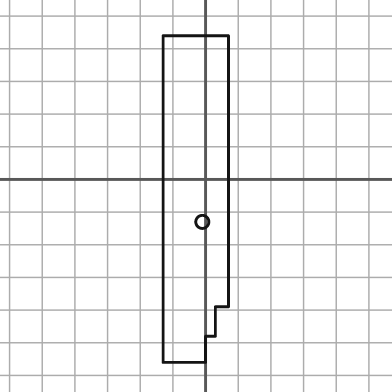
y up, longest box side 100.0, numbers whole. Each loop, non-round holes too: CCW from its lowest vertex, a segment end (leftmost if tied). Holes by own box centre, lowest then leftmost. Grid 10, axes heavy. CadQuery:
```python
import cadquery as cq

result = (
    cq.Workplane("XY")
    .moveTo(-13.0, -56.0)
    .lineTo(0.0, -56.0)
    .lineTo(0.0, -48.0)
    .lineTo(3.0, -48.0)
    .lineTo(3.0, -39.0)
    .lineTo(7.0, -39.0)
    .lineTo(7.0, 44.0)
    .lineTo(-13.0, 44.0)
    .close()
    .moveTo(-1.0, -13.0)
    .circle(2.0)
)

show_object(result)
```